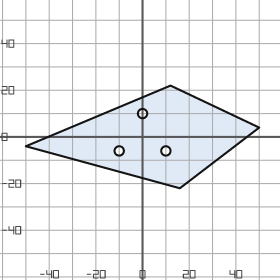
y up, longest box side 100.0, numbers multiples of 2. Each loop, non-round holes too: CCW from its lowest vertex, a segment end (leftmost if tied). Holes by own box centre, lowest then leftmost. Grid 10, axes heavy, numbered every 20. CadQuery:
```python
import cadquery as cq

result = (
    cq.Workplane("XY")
    .moveTo(16.0, -22.0)
    .lineTo(50.0, 4.0)
    .lineTo(12.0, 22.0)
    .lineTo(-50.0, -4.0)
    .close()
    .moveTo(-10.0, -6.0)
    .circle(2.0)
    .moveTo(10.0, -6.0)
    .circle(2.0)
    .moveTo(0.0, 10.0)
    .circle(2.0)
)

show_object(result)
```